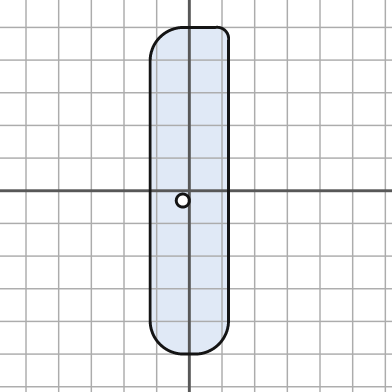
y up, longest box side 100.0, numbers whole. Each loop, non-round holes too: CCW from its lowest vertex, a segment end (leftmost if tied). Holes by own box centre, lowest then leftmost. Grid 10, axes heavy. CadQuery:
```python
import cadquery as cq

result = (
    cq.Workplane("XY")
    .moveTo(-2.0, -50.0)
    .lineTo(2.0, -50.0)
    .threePointArc((9.0, -47.0), (12.0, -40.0))
    .lineTo(12.0, 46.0)
    .threePointArc((11.0, 49.0), (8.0, 50.0))
    .lineTo(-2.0, 50.0)
    .threePointArc((-9.0, 47.0), (-12.0, 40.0))
    .lineTo(-12.0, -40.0)
    .threePointArc((-9.0, -47.0), (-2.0, -50.0))
    .close()
    .moveTo(-2.0, -3.0)
    .circle(2.0)
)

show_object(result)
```